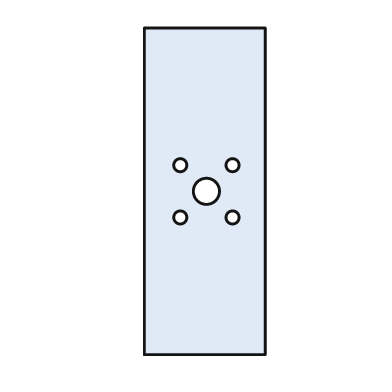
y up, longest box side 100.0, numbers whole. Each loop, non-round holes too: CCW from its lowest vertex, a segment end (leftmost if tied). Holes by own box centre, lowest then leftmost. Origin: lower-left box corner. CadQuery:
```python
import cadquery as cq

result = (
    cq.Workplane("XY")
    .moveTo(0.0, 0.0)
    .lineTo(37.0, 0.0)
    .lineTo(37.0, 100.0)
    .lineTo(0.0, 100.0)
    .close()
    .moveTo(11.0, 42.0)
    .circle(2.0)
    .moveTo(27.0, 42.0)
    .circle(2.0)
    .moveTo(19.0, 50.0)
    .circle(4.0)
    .moveTo(11.0, 58.0)
    .circle(2.0)
    .moveTo(27.0, 58.0)
    .circle(2.0)
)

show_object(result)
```